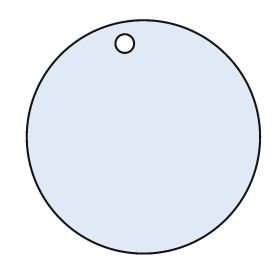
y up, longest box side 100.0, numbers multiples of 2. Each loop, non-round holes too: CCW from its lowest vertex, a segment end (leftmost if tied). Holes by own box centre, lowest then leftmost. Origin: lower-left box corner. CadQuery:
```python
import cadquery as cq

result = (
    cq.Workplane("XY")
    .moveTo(50.0, 50.0)
    .circle(50.0)
    .moveTo(42.0, 90.0)
    .circle(4.0)
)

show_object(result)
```